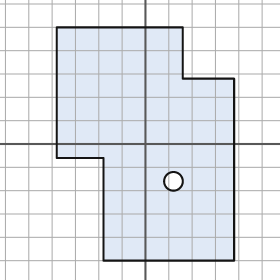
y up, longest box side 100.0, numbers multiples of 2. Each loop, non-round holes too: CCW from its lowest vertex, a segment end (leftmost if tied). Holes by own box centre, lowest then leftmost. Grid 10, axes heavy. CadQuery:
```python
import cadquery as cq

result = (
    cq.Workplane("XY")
    .moveTo(-18.0, -50.0)
    .lineTo(38.0, -50.0)
    .lineTo(38.0, 28.0)
    .lineTo(16.0, 28.0)
    .lineTo(16.0, 50.0)
    .lineTo(-38.0, 50.0)
    .lineTo(-38.0, -6.0)
    .lineTo(-18.0, -6.0)
    .close()
    .moveTo(12.0, -16.0)
    .circle(4.0)
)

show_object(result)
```